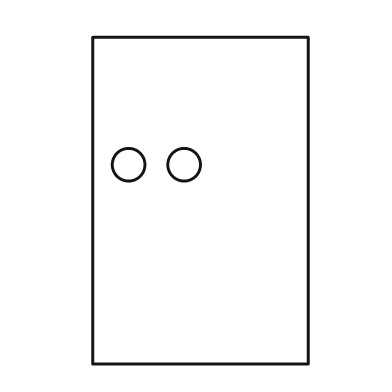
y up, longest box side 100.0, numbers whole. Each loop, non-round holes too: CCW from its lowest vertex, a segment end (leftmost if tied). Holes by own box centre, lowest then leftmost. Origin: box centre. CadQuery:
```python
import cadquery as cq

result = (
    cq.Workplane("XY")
    .moveTo(-33.0, -50.0)
    .lineTo(33.0, -50.0)
    .lineTo(33.0, 50.0)
    .lineTo(-33.0, 50.0)
    .close()
    .moveTo(-22.0, 11.0)
    .circle(5.0)
    .moveTo(-5.0, 11.0)
    .circle(5.0)
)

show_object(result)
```